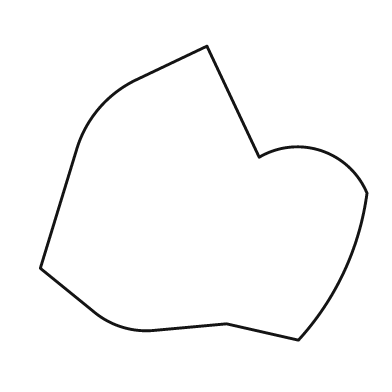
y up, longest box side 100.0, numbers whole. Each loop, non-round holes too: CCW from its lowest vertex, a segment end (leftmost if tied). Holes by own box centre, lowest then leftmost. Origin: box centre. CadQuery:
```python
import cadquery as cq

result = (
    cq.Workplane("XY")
    .moveTo(29.0, -45.0)
    .threePointArc((43.0, -24.0), (50.0, 0.0))
    .threePointArc((36.0, 13.0), (17.0, 11.0))
    .lineTo(1.0, 45.0)
    .lineTo(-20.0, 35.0)
    .threePointArc((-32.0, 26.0), (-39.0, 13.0))
    .lineTo(-50.0, -23.0)
    .lineTo(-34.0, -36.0)
    .threePointArc((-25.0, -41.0), (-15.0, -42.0))
    .lineTo(7.0, -40.0)
    .close()
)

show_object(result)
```